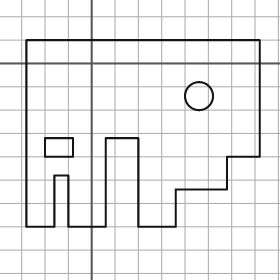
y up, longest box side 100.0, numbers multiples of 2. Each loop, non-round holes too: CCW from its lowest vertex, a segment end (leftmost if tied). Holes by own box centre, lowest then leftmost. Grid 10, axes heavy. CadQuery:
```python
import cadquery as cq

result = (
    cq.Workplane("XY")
    .moveTo(-28.0, -70.0)
    .lineTo(-16.0, -70.0)
    .lineTo(-16.0, -48.0)
    .lineTo(-10.0, -48.0)
    .lineTo(-10.0, -70.0)
    .lineTo(6.0, -70.0)
    .lineTo(6.0, -32.0)
    .lineTo(20.0, -32.0)
    .lineTo(20.0, -70.0)
    .lineTo(36.0, -70.0)
    .lineTo(36.0, -54.0)
    .lineTo(58.0, -54.0)
    .lineTo(58.0, -40.0)
    .lineTo(72.0, -40.0)
    .lineTo(72.0, 10.0)
    .lineTo(-28.0, 10.0)
    .close()
    .moveTo(-20.0, -40.0)
    .lineTo(-8.0, -40.0)
    .lineTo(-8.0, -32.0)
    .lineTo(-20.0, -32.0)
    .close()
    .moveTo(46.0, -14.0)
    .circle(6.0)
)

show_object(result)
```